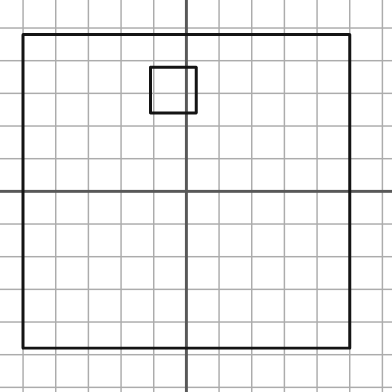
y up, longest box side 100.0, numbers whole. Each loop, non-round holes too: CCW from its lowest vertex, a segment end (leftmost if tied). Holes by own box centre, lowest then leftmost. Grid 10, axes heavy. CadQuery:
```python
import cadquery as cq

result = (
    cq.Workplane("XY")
    .moveTo(-50.0, -48.0)
    .lineTo(50.0, -48.0)
    .lineTo(50.0, 48.0)
    .lineTo(-50.0, 48.0)
    .close()
    .moveTo(-11.0, 24.0)
    .lineTo(3.0, 24.0)
    .lineTo(3.0, 38.0)
    .lineTo(-11.0, 38.0)
    .close()
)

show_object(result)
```